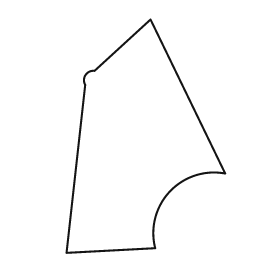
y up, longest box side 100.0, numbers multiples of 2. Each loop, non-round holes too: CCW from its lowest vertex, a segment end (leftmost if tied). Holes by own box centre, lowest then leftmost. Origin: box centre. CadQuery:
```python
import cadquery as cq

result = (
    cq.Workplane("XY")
    .moveTo(-34.0, -50.0)
    .lineTo(4.0, -48.0)
    .threePointArc((10.0, -24.0), (34.0, -16.0))
    .lineTo(2.0, 50.0)
    .lineTo(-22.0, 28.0)
    .threePointArc((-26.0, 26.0), (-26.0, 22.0))
    .close()
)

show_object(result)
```